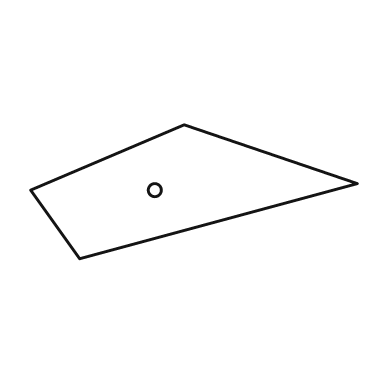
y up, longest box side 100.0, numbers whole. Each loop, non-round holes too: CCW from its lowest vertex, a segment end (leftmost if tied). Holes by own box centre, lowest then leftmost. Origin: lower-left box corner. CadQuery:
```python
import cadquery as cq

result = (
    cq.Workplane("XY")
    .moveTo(15.0, 0.0)
    .lineTo(100.0, 23.0)
    .lineTo(47.0, 41.0)
    .lineTo(0.0, 21.0)
    .close()
    .moveTo(38.0, 21.0)
    .circle(2.0)
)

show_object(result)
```